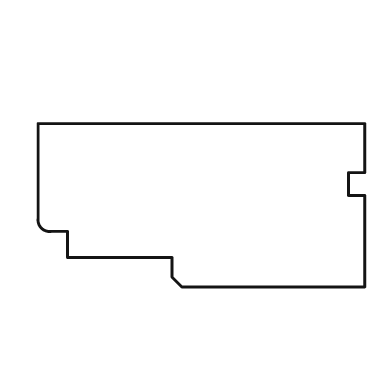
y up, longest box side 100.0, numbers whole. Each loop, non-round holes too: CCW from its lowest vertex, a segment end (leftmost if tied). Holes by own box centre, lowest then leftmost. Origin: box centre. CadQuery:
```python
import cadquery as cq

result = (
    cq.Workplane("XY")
    .moveTo(-6.0, -25.0)
    .lineTo(50.0, -25.0)
    .lineTo(50.0, 3.0)
    .lineTo(45.0, 3.0)
    .lineTo(45.0, 10.0)
    .lineTo(50.0, 10.0)
    .lineTo(50.0, 25.0)
    .lineTo(-50.0, 25.0)
    .lineTo(-50.0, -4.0)
    .threePointArc((-49.0, -7.0), (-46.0, -8.0))
    .lineTo(-41.0, -8.0)
    .lineTo(-41.0, -16.0)
    .lineTo(-9.0, -16.0)
    .lineTo(-9.0, -22.0)
    .close()
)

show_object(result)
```